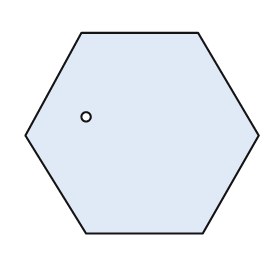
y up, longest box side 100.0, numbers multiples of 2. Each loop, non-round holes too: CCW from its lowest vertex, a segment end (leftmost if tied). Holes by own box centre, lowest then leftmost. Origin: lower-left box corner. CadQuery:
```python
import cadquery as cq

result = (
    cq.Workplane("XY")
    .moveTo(26.0, 0.0)
    .lineTo(76.0, 0.0)
    .lineTo(100.0, 42.0)
    .lineTo(74.0, 86.0)
    .lineTo(24.0, 86.0)
    .lineTo(0.0, 42.0)
    .close()
    .moveTo(26.0, 50.0)
    .circle(2.0)
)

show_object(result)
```